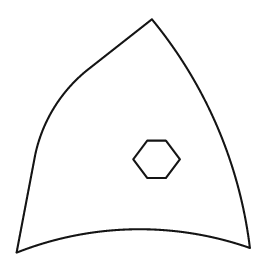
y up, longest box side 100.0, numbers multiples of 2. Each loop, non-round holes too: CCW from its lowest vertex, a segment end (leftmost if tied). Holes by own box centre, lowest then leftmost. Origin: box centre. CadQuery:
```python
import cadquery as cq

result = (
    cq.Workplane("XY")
    .moveTo(-50.0, -50.0)
    .threePointArc((0.0, -40.0), (50.0, -48.0))
    .threePointArc((36.0, 4.0), (8.0, 50.0))
    .lineTo(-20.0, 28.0)
    .threePointArc((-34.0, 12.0), (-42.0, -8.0))
    .close()
    .moveTo(6.0, -18.0)
    .lineTo(14.0, -18.0)
    .lineTo(20.0, -10.0)
    .lineTo(14.0, -2.0)
    .lineTo(6.0, -2.0)
    .lineTo(0.0, -10.0)
    .close()
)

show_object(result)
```